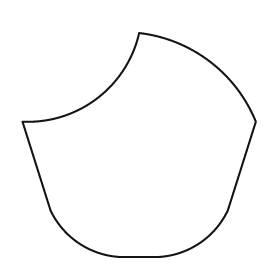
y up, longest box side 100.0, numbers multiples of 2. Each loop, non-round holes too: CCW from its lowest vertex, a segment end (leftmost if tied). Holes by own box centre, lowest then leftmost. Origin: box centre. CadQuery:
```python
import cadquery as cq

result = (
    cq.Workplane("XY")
    .moveTo(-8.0, -48.0)
    .lineTo(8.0, -48.0)
    .threePointArc((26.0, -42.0), (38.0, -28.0))
    .lineTo(50.0, 10.0)
    .threePointArc((30.0, 36.0), (0.0, 48.0))
    .threePointArc((-18.0, 20.0), (-50.0, 10.0))
    .lineTo(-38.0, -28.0)
    .threePointArc((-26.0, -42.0), (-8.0, -48.0))
    .close()
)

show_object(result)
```